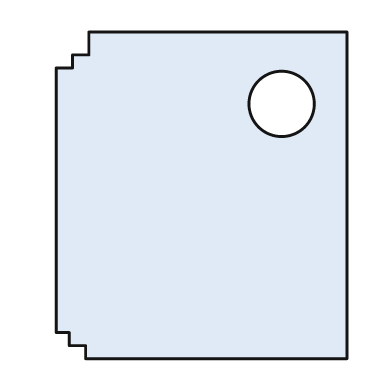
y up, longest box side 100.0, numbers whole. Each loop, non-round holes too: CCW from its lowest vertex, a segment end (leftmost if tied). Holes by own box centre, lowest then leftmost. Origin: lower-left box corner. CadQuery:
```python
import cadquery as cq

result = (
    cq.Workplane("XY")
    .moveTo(9.0, 0.0)
    .lineTo(89.0, 0.0)
    .lineTo(89.0, 100.0)
    .lineTo(10.0, 100.0)
    .lineTo(10.0, 93.0)
    .lineTo(5.0, 93.0)
    .lineTo(5.0, 89.0)
    .lineTo(0.0, 89.0)
    .lineTo(0.0, 8.0)
    .lineTo(4.0, 8.0)
    .lineTo(4.0, 4.0)
    .lineTo(9.0, 4.0)
    .close()
    .moveTo(69.0, 78.0)
    .circle(10.0)
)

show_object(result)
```